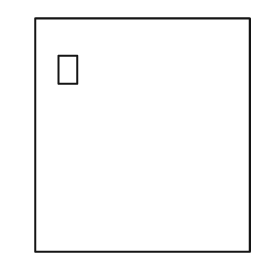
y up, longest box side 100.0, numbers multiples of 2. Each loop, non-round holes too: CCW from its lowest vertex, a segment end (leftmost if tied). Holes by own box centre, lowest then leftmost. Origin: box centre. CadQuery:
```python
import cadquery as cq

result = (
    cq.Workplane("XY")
    .moveTo(-46.0, -50.0)
    .lineTo(46.0, -50.0)
    .lineTo(46.0, 50.0)
    .lineTo(-46.0, 50.0)
    .close()
    .moveTo(-36.0, 22.0)
    .lineTo(-28.0, 22.0)
    .lineTo(-28.0, 34.0)
    .lineTo(-36.0, 34.0)
    .close()
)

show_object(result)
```